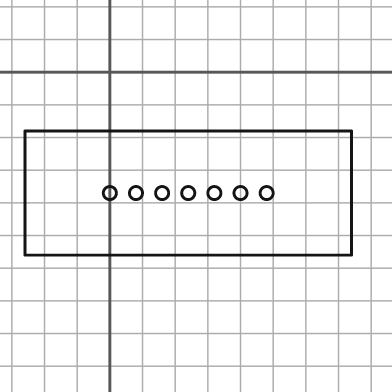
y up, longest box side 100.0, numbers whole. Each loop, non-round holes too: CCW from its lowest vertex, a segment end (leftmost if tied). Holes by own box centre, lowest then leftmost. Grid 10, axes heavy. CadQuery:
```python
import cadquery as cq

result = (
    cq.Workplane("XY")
    .moveTo(-26.0, -56.0)
    .lineTo(74.0, -56.0)
    .lineTo(74.0, -18.0)
    .lineTo(-26.0, -18.0)
    .close()
    .moveTo(0.0, -37.0)
    .circle(2.0)
    .moveTo(8.0, -37.0)
    .circle(2.0)
    .moveTo(16.0, -37.0)
    .circle(2.0)
    .moveTo(24.0, -37.0)
    .circle(2.0)
    .moveTo(32.0, -37.0)
    .circle(2.0)
    .moveTo(40.0, -37.0)
    .circle(2.0)
    .moveTo(48.0, -37.0)
    .circle(2.0)
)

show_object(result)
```